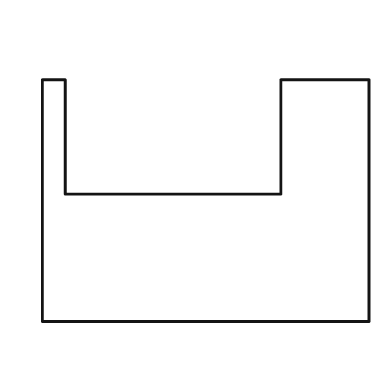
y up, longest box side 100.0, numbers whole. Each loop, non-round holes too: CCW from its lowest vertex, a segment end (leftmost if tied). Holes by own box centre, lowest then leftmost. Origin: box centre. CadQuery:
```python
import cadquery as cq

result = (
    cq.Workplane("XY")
    .moveTo(-50.0, -37.0)
    .lineTo(50.0, -37.0)
    .lineTo(50.0, 37.0)
    .lineTo(23.0, 37.0)
    .lineTo(23.0, 2.0)
    .lineTo(-43.0, 2.0)
    .lineTo(-43.0, 37.0)
    .lineTo(-50.0, 37.0)
    .close()
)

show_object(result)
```